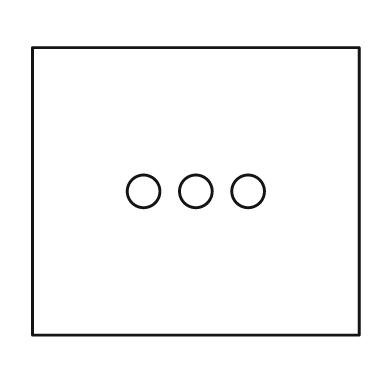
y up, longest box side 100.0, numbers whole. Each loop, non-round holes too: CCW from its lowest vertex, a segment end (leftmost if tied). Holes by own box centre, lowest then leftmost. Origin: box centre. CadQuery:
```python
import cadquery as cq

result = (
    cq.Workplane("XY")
    .moveTo(-50.0, -44.0)
    .lineTo(50.0, -44.0)
    .lineTo(50.0, 44.0)
    .lineTo(-50.0, 44.0)
    .close()
    .moveTo(-16.0, 0.0)
    .circle(5.0)
    .moveTo(0.0, 0.0)
    .circle(5.0)
    .moveTo(16.0, 0.0)
    .circle(5.0)
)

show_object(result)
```